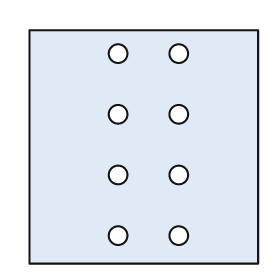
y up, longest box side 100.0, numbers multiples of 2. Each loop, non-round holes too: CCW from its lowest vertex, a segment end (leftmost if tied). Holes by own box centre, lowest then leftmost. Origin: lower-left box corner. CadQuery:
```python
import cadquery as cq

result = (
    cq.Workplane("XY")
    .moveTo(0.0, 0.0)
    .lineTo(98.0, 0.0)
    .lineTo(98.0, 100.0)
    .lineTo(0.0, 100.0)
    .close()
    .moveTo(38.0, 12.0)
    .circle(4.0)
    .moveTo(64.0, 12.0)
    .circle(4.0)
    .moveTo(38.0, 38.0)
    .circle(4.0)
    .moveTo(64.0, 38.0)
    .circle(4.0)
    .moveTo(38.0, 64.0)
    .circle(4.0)
    .moveTo(64.0, 64.0)
    .circle(4.0)
    .moveTo(38.0, 90.0)
    .circle(4.0)
    .moveTo(64.0, 90.0)
    .circle(4.0)
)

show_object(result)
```